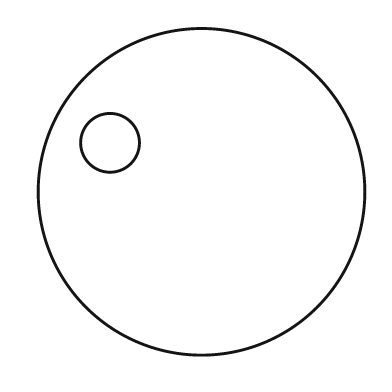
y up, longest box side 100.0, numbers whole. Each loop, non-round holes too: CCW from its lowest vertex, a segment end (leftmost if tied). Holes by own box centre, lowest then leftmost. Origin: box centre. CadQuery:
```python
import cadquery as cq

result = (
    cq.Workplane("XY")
    .moveTo(0.0, 0.0)
    .circle(50.0)
    .moveTo(-28.0, 15.0)
    .circle(9.0)
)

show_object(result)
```